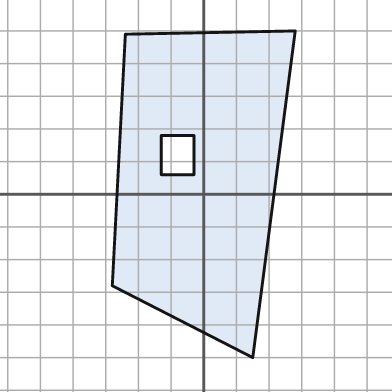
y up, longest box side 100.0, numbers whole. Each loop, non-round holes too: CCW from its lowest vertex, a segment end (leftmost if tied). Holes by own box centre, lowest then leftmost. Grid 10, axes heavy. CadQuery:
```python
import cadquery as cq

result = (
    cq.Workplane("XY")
    .moveTo(15.0, -50.0)
    .lineTo(28.0, 50.0)
    .lineTo(-24.0, 49.0)
    .lineTo(-28.0, -28.0)
    .close()
    .moveTo(-13.0, 6.0)
    .lineTo(-3.0, 6.0)
    .lineTo(-3.0, 18.0)
    .lineTo(-13.0, 18.0)
    .close()
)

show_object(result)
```